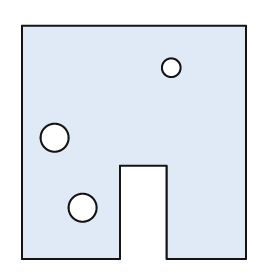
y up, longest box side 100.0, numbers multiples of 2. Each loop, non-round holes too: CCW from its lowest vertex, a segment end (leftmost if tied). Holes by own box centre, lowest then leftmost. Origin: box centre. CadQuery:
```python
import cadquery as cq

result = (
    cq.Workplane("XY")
    .moveTo(-48.0, -50.0)
    .lineTo(-6.0, -50.0)
    .lineTo(-6.0, -10.0)
    .lineTo(14.0, -10.0)
    .lineTo(14.0, -50.0)
    .lineTo(48.0, -50.0)
    .lineTo(48.0, 50.0)
    .lineTo(-48.0, 50.0)
    .close()
    .moveTo(-22.0, -28.0)
    .circle(6.0)
    .moveTo(-34.0, 2.0)
    .circle(6.0)
    .moveTo(16.0, 32.0)
    .circle(4.0)
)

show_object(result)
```